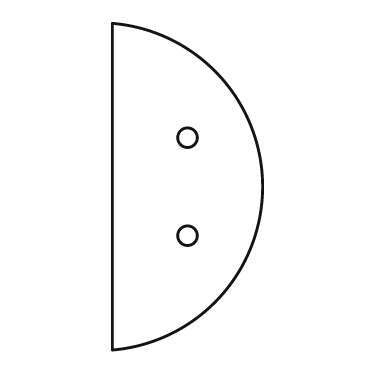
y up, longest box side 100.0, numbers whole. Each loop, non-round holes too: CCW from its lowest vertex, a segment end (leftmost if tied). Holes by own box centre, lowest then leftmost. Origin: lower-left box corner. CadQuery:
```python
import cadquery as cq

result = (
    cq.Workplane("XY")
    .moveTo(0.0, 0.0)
    .threePointArc((46.0, 50.0), (0.0, 100.0))
    .close()
    .moveTo(23.0, 35.0)
    .circle(3.0)
    .moveTo(23.0, 65.0)
    .circle(3.0)
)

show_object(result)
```